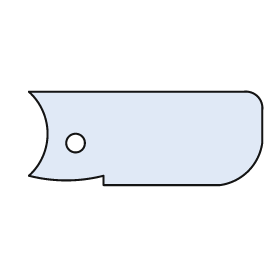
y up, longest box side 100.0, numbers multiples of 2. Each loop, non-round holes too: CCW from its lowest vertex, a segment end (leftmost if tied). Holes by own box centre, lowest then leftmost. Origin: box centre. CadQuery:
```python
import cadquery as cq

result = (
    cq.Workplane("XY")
    .moveTo(-18.0, -20.0)
    .lineTo(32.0, -20.0)
    .threePointArc((44.0, -14.0), (50.0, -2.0))
    .lineTo(50.0, 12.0)
    .threePointArc((48.0, 18.0), (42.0, 20.0))
    .lineTo(-50.0, 20.0)
    .threePointArc((-42.0, 2.0), (-50.0, -16.0))
    .threePointArc((-34.0, -18.0), (-18.0, -16.0))
    .close()
    .moveTo(-30.0, -2.0)
    .circle(4.0)
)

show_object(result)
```